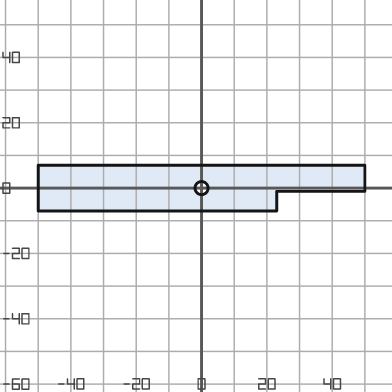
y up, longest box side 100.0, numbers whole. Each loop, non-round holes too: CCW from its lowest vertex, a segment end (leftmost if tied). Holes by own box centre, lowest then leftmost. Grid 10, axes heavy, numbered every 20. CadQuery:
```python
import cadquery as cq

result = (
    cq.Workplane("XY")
    .moveTo(-50.0, -7.0)
    .lineTo(23.0, -7.0)
    .lineTo(23.0, -1.0)
    .lineTo(50.0, -1.0)
    .lineTo(50.0, 7.0)
    .lineTo(-50.0, 7.0)
    .close()
    .moveTo(0.0, 0.0)
    .circle(2.0)
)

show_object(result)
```